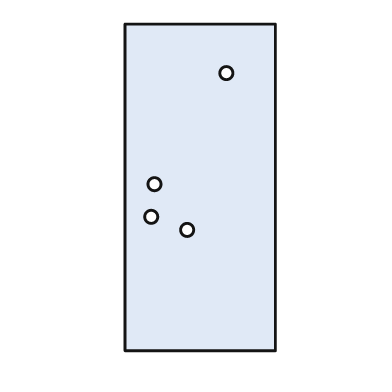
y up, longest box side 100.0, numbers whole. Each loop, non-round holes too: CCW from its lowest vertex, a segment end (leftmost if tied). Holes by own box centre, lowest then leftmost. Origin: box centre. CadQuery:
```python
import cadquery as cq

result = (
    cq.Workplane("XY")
    .moveTo(-23.0, -50.0)
    .lineTo(23.0, -50.0)
    .lineTo(23.0, 50.0)
    .lineTo(-23.0, 50.0)
    .close()
    .moveTo(-4.0, -13.0)
    .circle(2.0)
    .moveTo(-15.0, -9.0)
    .circle(2.0)
    .moveTo(-14.0, 1.0)
    .circle(2.0)
    .moveTo(8.0, 35.0)
    .circle(2.0)
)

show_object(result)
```